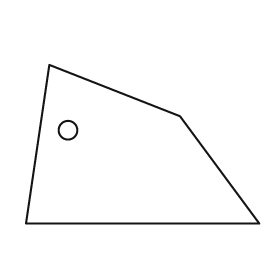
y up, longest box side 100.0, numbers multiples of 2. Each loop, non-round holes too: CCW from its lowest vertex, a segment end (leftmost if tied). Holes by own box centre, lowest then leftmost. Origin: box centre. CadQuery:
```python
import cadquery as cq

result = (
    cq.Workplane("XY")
    .moveTo(-50.0, -34.0)
    .lineTo(50.0, -34.0)
    .lineTo(16.0, 12.0)
    .lineTo(-40.0, 34.0)
    .close()
    .moveTo(-32.0, 6.0)
    .circle(4.0)
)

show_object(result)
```